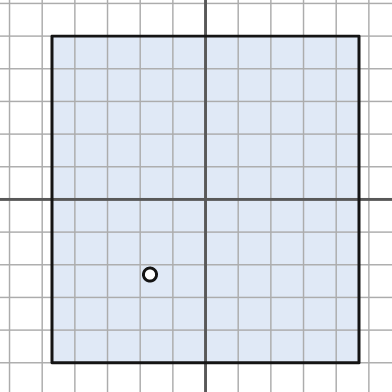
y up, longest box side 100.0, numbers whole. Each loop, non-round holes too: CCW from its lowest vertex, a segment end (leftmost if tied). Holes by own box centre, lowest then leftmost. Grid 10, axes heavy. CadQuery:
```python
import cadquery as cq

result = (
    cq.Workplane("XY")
    .moveTo(-47.0, -50.0)
    .lineTo(47.0, -50.0)
    .lineTo(47.0, 50.0)
    .lineTo(-47.0, 50.0)
    .close()
    .moveTo(-17.0, -23.0)
    .circle(2.0)
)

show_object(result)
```